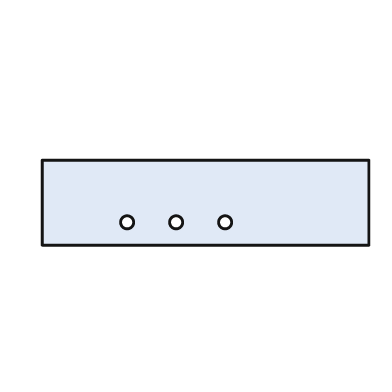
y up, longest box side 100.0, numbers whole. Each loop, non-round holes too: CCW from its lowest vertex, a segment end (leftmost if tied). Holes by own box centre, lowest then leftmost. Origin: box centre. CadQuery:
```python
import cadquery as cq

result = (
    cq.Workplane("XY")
    .moveTo(-50.0, -13.0)
    .lineTo(50.0, -13.0)
    .lineTo(50.0, 13.0)
    .lineTo(-50.0, 13.0)
    .close()
    .moveTo(-24.0, -6.0)
    .circle(2.0)
    .moveTo(-9.0, -6.0)
    .circle(2.0)
    .moveTo(6.0, -6.0)
    .circle(2.0)
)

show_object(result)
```